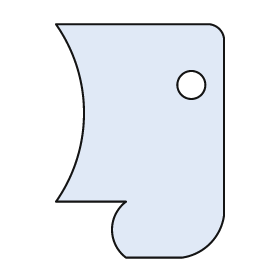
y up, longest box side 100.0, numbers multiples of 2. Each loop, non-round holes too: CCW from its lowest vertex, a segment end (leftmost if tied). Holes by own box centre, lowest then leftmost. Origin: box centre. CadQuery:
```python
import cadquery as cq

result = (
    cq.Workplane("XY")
    .moveTo(-6.0, -50.0)
    .lineTo(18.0, -50.0)
    .threePointArc((30.0, -44.0), (36.0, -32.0))
    .lineTo(36.0, 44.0)
    .threePointArc((34.0, 48.0), (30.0, 50.0))
    .lineTo(-36.0, 50.0)
    .threePointArc((-24.0, 12.0), (-36.0, -26.0))
    .lineTo(-6.0, -26.0)
    .threePointArc((-12.0, -38.0), (-6.0, -50.0))
    .close()
    .moveTo(22.0, 24.0)
    .circle(6.0)
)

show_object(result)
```